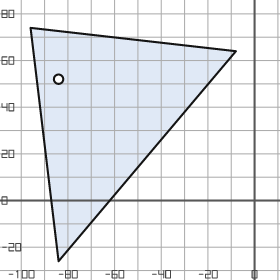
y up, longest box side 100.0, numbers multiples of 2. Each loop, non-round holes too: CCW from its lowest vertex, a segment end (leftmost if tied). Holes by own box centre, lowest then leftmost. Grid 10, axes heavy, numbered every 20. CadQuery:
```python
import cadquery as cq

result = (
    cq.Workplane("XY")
    .moveTo(-84.0, -26.0)
    .lineTo(-8.0, 64.0)
    .lineTo(-96.0, 74.0)
    .close()
    .moveTo(-84.0, 52.0)
    .circle(2.0)
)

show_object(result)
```